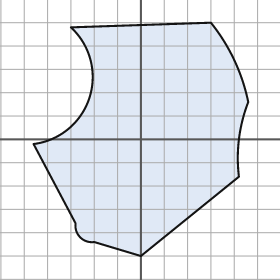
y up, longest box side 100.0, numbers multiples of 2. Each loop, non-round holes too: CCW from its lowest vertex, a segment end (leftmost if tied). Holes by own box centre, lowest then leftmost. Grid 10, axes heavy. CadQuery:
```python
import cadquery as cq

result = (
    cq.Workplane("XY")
    .moveTo(0.0, -50.0)
    .lineTo(42.0, -16.0)
    .threePointArc((42.0, 0.0), (46.0, 16.0))
    .threePointArc((40.0, 34.0), (30.0, 50.0))
    .lineTo(-30.0, 48.0)
    .threePointArc((-22.0, 18.0), (-46.0, -2.0))
    .lineTo(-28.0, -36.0)
    .threePointArc((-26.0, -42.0), (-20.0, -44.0))
    .close()
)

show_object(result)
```